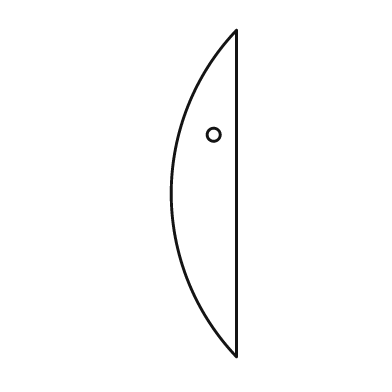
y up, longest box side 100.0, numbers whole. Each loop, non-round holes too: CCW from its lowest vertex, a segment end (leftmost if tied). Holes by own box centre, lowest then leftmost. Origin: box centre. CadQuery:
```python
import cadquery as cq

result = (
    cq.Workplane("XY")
    .moveTo(10.0, -50.0)
    .lineTo(10.0, 50.0)
    .threePointArc((-10.0, 0.0), (10.0, -50.0))
    .close()
    .moveTo(3.0, 18.0)
    .circle(2.0)
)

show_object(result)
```